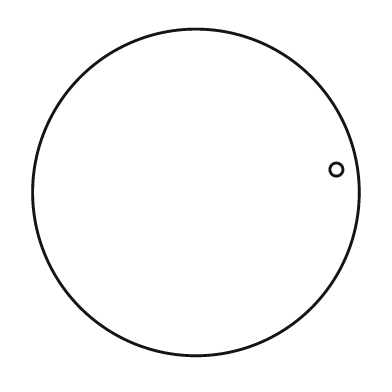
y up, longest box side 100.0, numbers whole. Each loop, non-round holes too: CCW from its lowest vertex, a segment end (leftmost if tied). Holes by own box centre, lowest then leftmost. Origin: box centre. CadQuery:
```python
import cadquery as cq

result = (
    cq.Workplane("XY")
    .moveTo(0.0, 0.0)
    .circle(50.0)
    .moveTo(43.0, 7.0)
    .circle(2.0)
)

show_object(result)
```